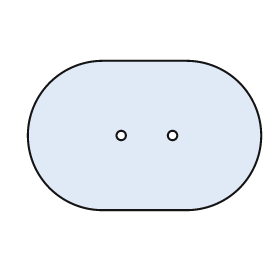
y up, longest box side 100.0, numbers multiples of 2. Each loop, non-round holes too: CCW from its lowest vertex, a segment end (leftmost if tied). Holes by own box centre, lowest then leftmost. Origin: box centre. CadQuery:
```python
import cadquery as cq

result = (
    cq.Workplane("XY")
    .moveTo(-18.0, -32.0)
    .lineTo(18.0, -32.0)
    .threePointArc((50.0, 0.0), (18.0, 32.0))
    .lineTo(-18.0, 32.0)
    .threePointArc((-50.0, 0.0), (-18.0, -32.0))
    .close()
    .moveTo(-10.0, 0.0)
    .circle(2.0)
    .moveTo(12.0, 0.0)
    .circle(2.0)
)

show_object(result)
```